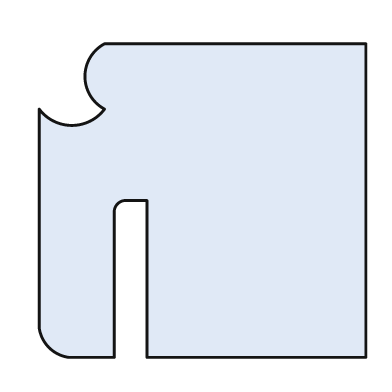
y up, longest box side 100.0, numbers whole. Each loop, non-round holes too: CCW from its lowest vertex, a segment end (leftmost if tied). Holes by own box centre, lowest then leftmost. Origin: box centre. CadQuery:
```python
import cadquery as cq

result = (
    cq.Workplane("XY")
    .moveTo(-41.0, -48.0)
    .lineTo(-27.0, -48.0)
    .lineTo(-27.0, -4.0)
    .threePointArc((-26.0, -1.0), (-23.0, 0.0))
    .lineTo(-17.0, 0.0)
    .lineTo(-17.0, -48.0)
    .lineTo(50.0, -48.0)
    .lineTo(50.0, 48.0)
    .lineTo(-30.0, 48.0)
    .threePointArc((-36.0, 38.0), (-30.0, 28.0))
    .threePointArc((-40.0, 23.0), (-50.0, 28.0))
    .lineTo(-50.0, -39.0)
    .threePointArc((-47.0, -45.0), (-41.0, -48.0))
    .close()
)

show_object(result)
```